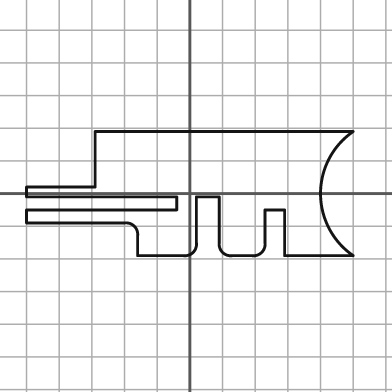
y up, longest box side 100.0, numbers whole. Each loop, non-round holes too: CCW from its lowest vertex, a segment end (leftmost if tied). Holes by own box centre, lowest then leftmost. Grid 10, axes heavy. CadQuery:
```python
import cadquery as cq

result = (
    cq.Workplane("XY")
    .moveTo(-16.0, -19.0)
    .lineTo(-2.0, -19.0)
    .threePointArc((1.0, -18.0), (2.0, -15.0))
    .lineTo(2.0, -1.0)
    .lineTo(9.0, -1.0)
    .lineTo(9.0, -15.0)
    .threePointArc((10.0, -18.0), (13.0, -19.0))
    .lineTo(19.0, -19.0)
    .threePointArc((22.0, -18.0), (23.0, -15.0))
    .lineTo(23.0, -5.0)
    .lineTo(29.0, -5.0)
    .lineTo(29.0, -19.0)
    .lineTo(50.0, -19.0)
    .threePointArc((40.0, 0.0), (50.0, 19.0))
    .lineTo(-29.0, 19.0)
    .lineTo(-29.0, 2.0)
    .lineTo(-50.0, 2.0)
    .lineTo(-50.0, -1.0)
    .lineTo(-4.0, -1.0)
    .lineTo(-4.0, -5.0)
    .lineTo(-50.0, -5.0)
    .lineTo(-50.0, -9.0)
    .lineTo(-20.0, -9.0)
    .threePointArc((-17.0, -10.0), (-16.0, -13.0))
    .close()
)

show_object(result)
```